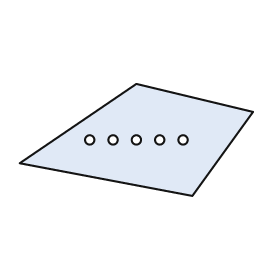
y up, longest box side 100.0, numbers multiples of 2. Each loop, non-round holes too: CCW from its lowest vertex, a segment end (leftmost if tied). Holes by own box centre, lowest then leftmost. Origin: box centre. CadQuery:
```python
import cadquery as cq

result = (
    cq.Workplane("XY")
    .moveTo(24.0, -24.0)
    .lineTo(50.0, 12.0)
    .lineTo(0.0, 24.0)
    .lineTo(-50.0, -10.0)
    .close()
    .moveTo(-20.0, 0.0)
    .circle(2.0)
    .moveTo(-10.0, 0.0)
    .circle(2.0)
    .moveTo(0.0, 0.0)
    .circle(2.0)
    .moveTo(10.0, 0.0)
    .circle(2.0)
    .moveTo(20.0, 0.0)
    .circle(2.0)
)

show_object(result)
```